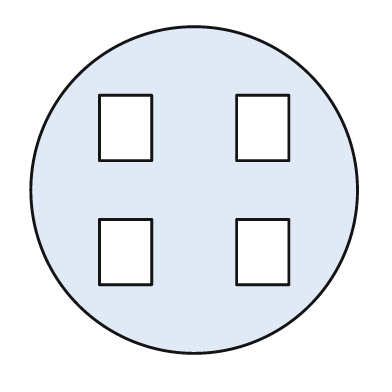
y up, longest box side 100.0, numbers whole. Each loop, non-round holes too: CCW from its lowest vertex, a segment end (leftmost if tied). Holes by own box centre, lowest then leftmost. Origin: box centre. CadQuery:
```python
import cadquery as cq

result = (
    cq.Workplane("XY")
    .moveTo(0.0, 0.0)
    .circle(50.0)
    .moveTo(-29.0, -29.0)
    .lineTo(-13.0, -29.0)
    .lineTo(-13.0, -9.0)
    .lineTo(-29.0, -9.0)
    .close()
    .moveTo(13.0, -29.0)
    .lineTo(29.0, -29.0)
    .lineTo(29.0, -9.0)
    .lineTo(13.0, -9.0)
    .close()
    .moveTo(-29.0, 9.0)
    .lineTo(-13.0, 9.0)
    .lineTo(-13.0, 29.0)
    .lineTo(-29.0, 29.0)
    .close()
    .moveTo(13.0, 9.0)
    .lineTo(29.0, 9.0)
    .lineTo(29.0, 29.0)
    .lineTo(13.0, 29.0)
    .close()
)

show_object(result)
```